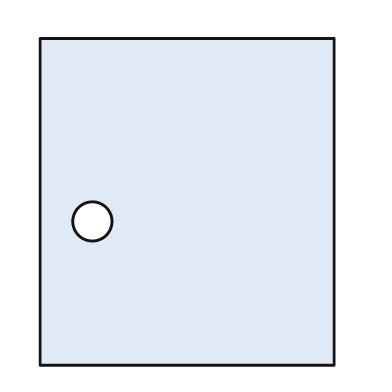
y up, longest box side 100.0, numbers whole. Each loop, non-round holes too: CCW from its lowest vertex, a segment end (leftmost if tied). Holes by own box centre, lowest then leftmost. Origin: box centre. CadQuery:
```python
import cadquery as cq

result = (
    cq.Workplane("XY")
    .moveTo(-45.0, -50.0)
    .lineTo(45.0, -50.0)
    .lineTo(45.0, 50.0)
    .lineTo(-45.0, 50.0)
    .close()
    .moveTo(-29.0, -6.0)
    .circle(6.0)
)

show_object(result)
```